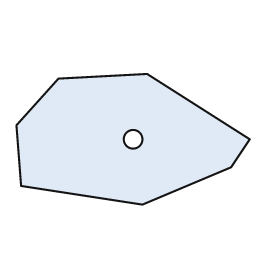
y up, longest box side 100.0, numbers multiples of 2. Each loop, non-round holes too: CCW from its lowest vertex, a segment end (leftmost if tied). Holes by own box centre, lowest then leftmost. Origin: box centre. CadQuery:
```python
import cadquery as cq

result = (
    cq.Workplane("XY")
    .moveTo(4.0, -28.0)
    .lineTo(42.0, -12.0)
    .lineTo(50.0, 0.0)
    .lineTo(6.0, 28.0)
    .lineTo(-32.0, 26.0)
    .lineTo(-50.0, 6.0)
    .lineTo(-48.0, -20.0)
    .close()
    .moveTo(0.0, 0.0)
    .circle(4.0)
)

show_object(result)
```